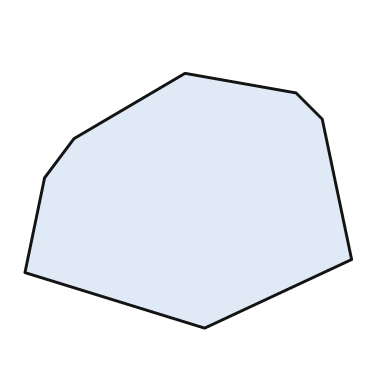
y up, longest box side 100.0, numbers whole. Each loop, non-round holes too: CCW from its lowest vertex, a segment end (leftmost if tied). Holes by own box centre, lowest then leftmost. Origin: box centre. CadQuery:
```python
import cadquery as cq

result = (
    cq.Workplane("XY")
    .moveTo(5.0, -39.0)
    .lineTo(50.0, -18.0)
    .lineTo(41.0, 25.0)
    .lineTo(33.0, 33.0)
    .lineTo(-1.0, 39.0)
    .lineTo(-35.0, 19.0)
    .lineTo(-44.0, 7.0)
    .lineTo(-50.0, -22.0)
    .close()
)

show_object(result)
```